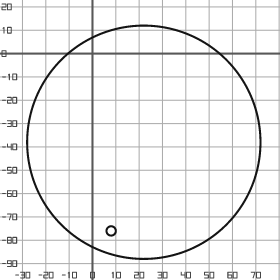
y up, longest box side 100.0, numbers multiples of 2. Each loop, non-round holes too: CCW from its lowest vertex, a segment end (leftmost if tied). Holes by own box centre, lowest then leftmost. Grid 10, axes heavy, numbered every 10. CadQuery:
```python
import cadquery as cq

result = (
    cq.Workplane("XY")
    .moveTo(22.0, -38.0)
    .circle(50.0)
    .moveTo(8.0, -76.0)
    .circle(2.0)
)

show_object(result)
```